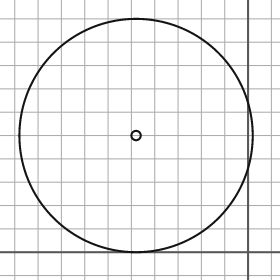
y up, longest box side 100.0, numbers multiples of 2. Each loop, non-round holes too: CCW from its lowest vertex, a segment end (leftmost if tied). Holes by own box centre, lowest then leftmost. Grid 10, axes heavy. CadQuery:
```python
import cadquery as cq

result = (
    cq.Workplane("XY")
    .moveTo(-48.0, 50.0)
    .circle(50.0)
    .moveTo(-48.0, 50.0)
    .circle(2.0)
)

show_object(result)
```